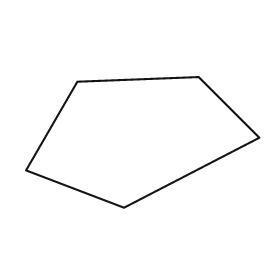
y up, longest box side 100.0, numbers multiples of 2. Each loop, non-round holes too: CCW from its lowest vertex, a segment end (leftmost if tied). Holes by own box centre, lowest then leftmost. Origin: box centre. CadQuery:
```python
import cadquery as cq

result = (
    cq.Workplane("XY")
    .moveTo(-8.0, -28.0)
    .lineTo(50.0, 2.0)
    .lineTo(24.0, 28.0)
    .lineTo(-28.0, 26.0)
    .lineTo(-50.0, -12.0)
    .close()
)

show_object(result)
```